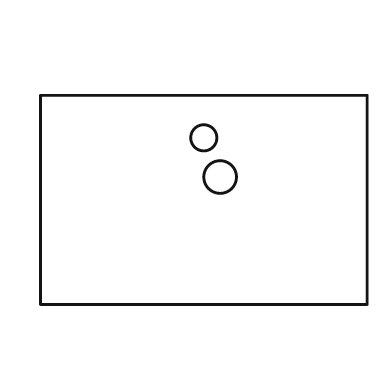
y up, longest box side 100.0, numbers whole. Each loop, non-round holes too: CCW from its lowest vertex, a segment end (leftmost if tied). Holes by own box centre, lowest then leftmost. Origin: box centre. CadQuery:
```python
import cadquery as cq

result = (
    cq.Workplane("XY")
    .moveTo(-50.0, -32.0)
    .lineTo(50.0, -32.0)
    .lineTo(50.0, 32.0)
    .lineTo(-50.0, 32.0)
    .close()
    .moveTo(5.0, 7.0)
    .circle(5.0)
    .moveTo(0.0, 19.0)
    .circle(4.0)
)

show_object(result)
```